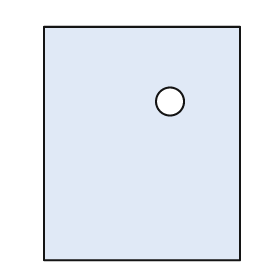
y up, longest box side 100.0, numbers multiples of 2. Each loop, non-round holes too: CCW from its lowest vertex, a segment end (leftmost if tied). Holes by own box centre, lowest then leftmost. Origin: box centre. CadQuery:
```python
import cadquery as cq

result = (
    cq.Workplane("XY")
    .moveTo(-42.0, -50.0)
    .lineTo(42.0, -50.0)
    .lineTo(42.0, 50.0)
    .lineTo(-42.0, 50.0)
    .close()
    .moveTo(12.0, 18.0)
    .circle(6.0)
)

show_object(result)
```